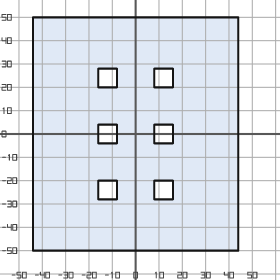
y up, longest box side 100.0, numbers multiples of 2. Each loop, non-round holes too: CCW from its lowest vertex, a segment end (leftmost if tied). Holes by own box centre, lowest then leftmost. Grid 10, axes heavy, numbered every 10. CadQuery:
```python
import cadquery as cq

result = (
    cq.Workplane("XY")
    .moveTo(-44.0, -50.0)
    .lineTo(44.0, -50.0)
    .lineTo(44.0, 50.0)
    .lineTo(-44.0, 50.0)
    .close()
    .moveTo(-16.0, -28.0)
    .lineTo(-8.0, -28.0)
    .lineTo(-8.0, -20.0)
    .lineTo(-16.0, -20.0)
    .close()
    .moveTo(8.0, -28.0)
    .lineTo(16.0, -28.0)
    .lineTo(16.0, -20.0)
    .lineTo(8.0, -20.0)
    .close()
    .moveTo(-16.0, -4.0)
    .lineTo(-8.0, -4.0)
    .lineTo(-8.0, 4.0)
    .lineTo(-16.0, 4.0)
    .close()
    .moveTo(8.0, -4.0)
    .lineTo(16.0, -4.0)
    .lineTo(16.0, 4.0)
    .lineTo(8.0, 4.0)
    .close()
    .moveTo(-16.0, 20.0)
    .lineTo(-8.0, 20.0)
    .lineTo(-8.0, 28.0)
    .lineTo(-16.0, 28.0)
    .close()
    .moveTo(8.0, 20.0)
    .lineTo(16.0, 20.0)
    .lineTo(16.0, 28.0)
    .lineTo(8.0, 28.0)
    .close()
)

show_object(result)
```